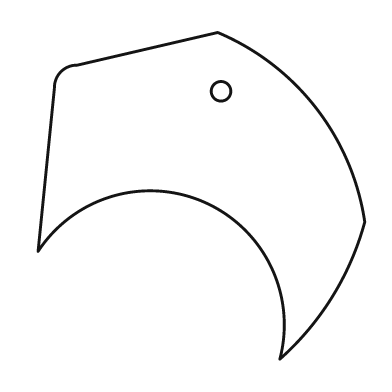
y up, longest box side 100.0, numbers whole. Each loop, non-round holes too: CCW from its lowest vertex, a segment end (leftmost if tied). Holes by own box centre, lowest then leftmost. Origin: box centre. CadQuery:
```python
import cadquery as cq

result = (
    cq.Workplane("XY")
    .moveTo(24.0, -50.0)
    .threePointArc((40.0, -31.0), (50.0, -8.0))
    .threePointArc((35.0, 27.0), (5.0, 50.0))
    .lineTo(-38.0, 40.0)
    .threePointArc((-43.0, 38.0), (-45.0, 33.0))
    .lineTo(-50.0, -17.0)
    .threePointArc((1.0, -2.0), (24.0, -50.0))
    .close()
    .moveTo(6.0, 32.0)
    .circle(3.0)
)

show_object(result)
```